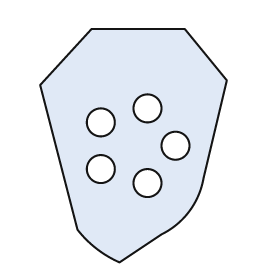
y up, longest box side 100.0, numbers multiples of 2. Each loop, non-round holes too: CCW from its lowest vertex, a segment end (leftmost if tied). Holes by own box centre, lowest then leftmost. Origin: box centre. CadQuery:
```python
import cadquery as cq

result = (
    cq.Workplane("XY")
    .moveTo(-6.0, -50.0)
    .lineTo(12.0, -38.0)
    .threePointArc((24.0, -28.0), (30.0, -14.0))
    .lineTo(40.0, 28.0)
    .lineTo(22.0, 50.0)
    .lineTo(-18.0, 50.0)
    .lineTo(-40.0, 26.0)
    .lineTo(-24.0, -36.0)
    .threePointArc((-16.0, -44.0), (-6.0, -50.0))
    .close()
    .moveTo(6.0, -16.0)
    .circle(6.0)
    .moveTo(-14.0, -10.0)
    .circle(6.0)
    .moveTo(18.0, 0.0)
    .circle(6.0)
    .moveTo(-14.0, 10.0)
    .circle(6.0)
    .moveTo(6.0, 16.0)
    .circle(6.0)
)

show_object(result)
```